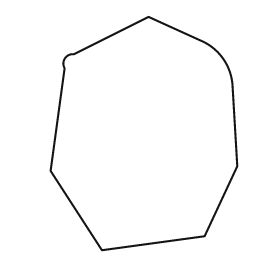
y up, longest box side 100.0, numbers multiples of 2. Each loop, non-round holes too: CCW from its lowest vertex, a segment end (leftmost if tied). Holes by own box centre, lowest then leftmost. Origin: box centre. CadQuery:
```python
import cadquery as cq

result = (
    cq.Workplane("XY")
    .moveTo(-18.0, -50.0)
    .lineTo(26.0, -44.0)
    .lineTo(40.0, -14.0)
    .lineTo(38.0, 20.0)
    .threePointArc((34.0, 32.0), (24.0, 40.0))
    .lineTo(2.0, 50.0)
    .lineTo(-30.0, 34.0)
    .threePointArc((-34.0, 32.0), (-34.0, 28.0))
    .lineTo(-40.0, -16.0)
    .close()
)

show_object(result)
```